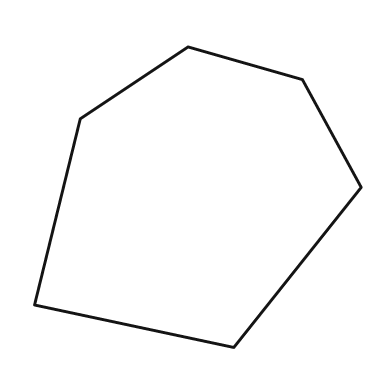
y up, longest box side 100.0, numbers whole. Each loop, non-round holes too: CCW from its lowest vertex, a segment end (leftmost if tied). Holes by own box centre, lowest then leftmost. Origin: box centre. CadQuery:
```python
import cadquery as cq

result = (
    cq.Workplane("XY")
    .moveTo(11.0, -46.0)
    .lineTo(50.0, 3.0)
    .lineTo(32.0, 36.0)
    .lineTo(-3.0, 46.0)
    .lineTo(-36.0, 24.0)
    .lineTo(-50.0, -33.0)
    .close()
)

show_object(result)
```